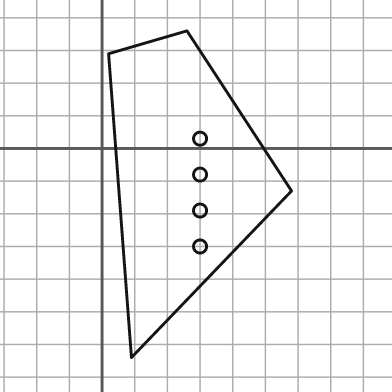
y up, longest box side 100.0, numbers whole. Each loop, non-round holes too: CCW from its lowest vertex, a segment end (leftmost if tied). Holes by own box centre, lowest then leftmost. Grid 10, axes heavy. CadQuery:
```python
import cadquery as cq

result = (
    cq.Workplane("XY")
    .moveTo(9.0, -64.0)
    .lineTo(58.0, -13.0)
    .lineTo(26.0, 36.0)
    .lineTo(2.0, 29.0)
    .close()
    .moveTo(30.0, -30.0)
    .circle(2.0)
    .moveTo(30.0, -19.0)
    .circle(2.0)
    .moveTo(30.0, -8.0)
    .circle(2.0)
    .moveTo(30.0, 3.0)
    .circle(2.0)
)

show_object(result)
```